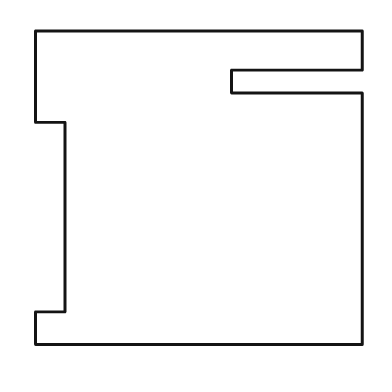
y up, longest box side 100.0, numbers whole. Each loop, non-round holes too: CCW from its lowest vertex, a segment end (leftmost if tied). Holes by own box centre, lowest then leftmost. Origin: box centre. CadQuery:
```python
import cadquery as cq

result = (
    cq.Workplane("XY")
    .moveTo(-50.0, -48.0)
    .lineTo(50.0, -48.0)
    .lineTo(50.0, 29.0)
    .lineTo(10.0, 29.0)
    .lineTo(10.0, 36.0)
    .lineTo(50.0, 36.0)
    .lineTo(50.0, 48.0)
    .lineTo(-50.0, 48.0)
    .lineTo(-50.0, 20.0)
    .lineTo(-41.0, 20.0)
    .lineTo(-41.0, -38.0)
    .lineTo(-50.0, -38.0)
    .close()
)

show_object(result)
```